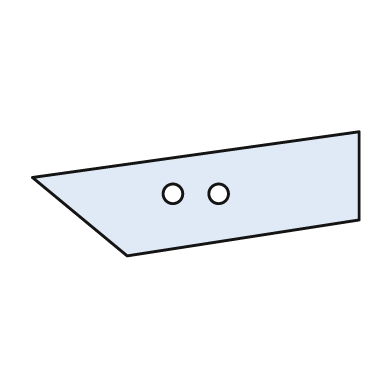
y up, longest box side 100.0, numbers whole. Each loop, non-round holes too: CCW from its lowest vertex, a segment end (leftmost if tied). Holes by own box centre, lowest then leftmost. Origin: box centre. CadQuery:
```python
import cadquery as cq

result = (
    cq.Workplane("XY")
    .moveTo(-21.0, -19.0)
    .lineTo(50.0, -8.0)
    .lineTo(50.0, 19.0)
    .lineTo(-50.0, 5.0)
    .close()
    .moveTo(-7.0, 0.0)
    .circle(3.0)
    .moveTo(7.0, 0.0)
    .circle(3.0)
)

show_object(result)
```